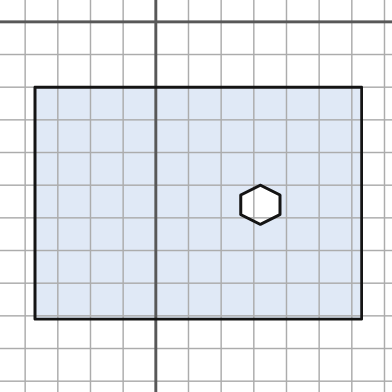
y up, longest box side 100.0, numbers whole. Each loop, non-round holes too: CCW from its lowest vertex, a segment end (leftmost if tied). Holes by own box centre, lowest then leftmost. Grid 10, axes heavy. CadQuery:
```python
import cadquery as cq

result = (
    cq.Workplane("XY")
    .moveTo(-37.0, -91.0)
    .lineTo(63.0, -91.0)
    .lineTo(63.0, -20.0)
    .lineTo(-37.0, -20.0)
    .close()
    .moveTo(32.0, -62.0)
    .lineTo(38.0, -59.0)
    .lineTo(38.0, -53.0)
    .lineTo(32.0, -50.0)
    .lineTo(26.0, -53.0)
    .lineTo(26.0, -59.0)
    .close()
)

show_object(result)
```